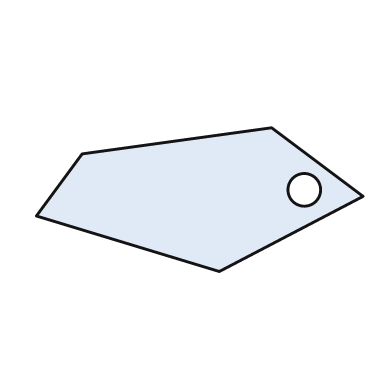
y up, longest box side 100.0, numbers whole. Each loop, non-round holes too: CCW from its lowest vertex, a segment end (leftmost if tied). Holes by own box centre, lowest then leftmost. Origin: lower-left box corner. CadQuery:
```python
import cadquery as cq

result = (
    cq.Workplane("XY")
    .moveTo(56.0, 0.0)
    .lineTo(100.0, 23.0)
    .lineTo(72.0, 44.0)
    .lineTo(14.0, 36.0)
    .lineTo(0.0, 17.0)
    .close()
    .moveTo(82.0, 25.0)
    .circle(5.0)
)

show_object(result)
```